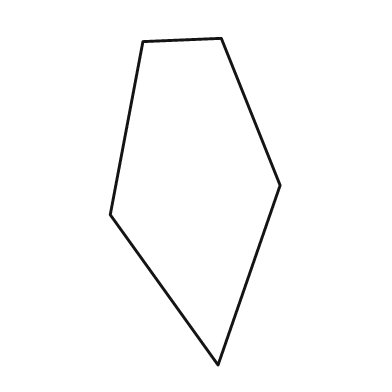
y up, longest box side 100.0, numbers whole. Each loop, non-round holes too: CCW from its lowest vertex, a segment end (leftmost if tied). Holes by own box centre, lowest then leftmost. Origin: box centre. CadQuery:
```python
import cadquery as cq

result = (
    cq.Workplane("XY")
    .moveTo(7.0, -50.0)
    .lineTo(26.0, 5.0)
    .lineTo(8.0, 50.0)
    .lineTo(-16.0, 49.0)
    .lineTo(-26.0, -4.0)
    .close()
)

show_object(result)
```